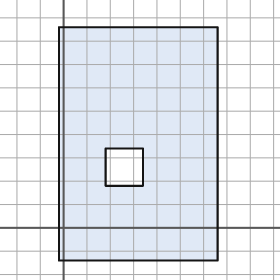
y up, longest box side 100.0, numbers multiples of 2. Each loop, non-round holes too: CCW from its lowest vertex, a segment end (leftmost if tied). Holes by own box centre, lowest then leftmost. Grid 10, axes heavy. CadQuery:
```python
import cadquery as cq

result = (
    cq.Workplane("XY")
    .moveTo(-2.0, -14.0)
    .lineTo(66.0, -14.0)
    .lineTo(66.0, 86.0)
    .lineTo(-2.0, 86.0)
    .close()
    .moveTo(18.0, 18.0)
    .lineTo(34.0, 18.0)
    .lineTo(34.0, 34.0)
    .lineTo(18.0, 34.0)
    .close()
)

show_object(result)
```